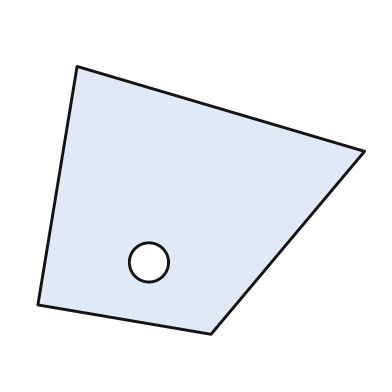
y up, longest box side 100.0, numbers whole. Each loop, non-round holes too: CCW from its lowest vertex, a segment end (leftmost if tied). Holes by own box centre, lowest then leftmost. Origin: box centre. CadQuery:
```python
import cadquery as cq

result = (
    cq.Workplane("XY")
    .moveTo(3.0, -41.0)
    .lineTo(50.0, 15.0)
    .lineTo(-38.0, 41.0)
    .lineTo(-50.0, -32.0)
    .close()
    .moveTo(-16.0, -19.0)
    .circle(6.0)
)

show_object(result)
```